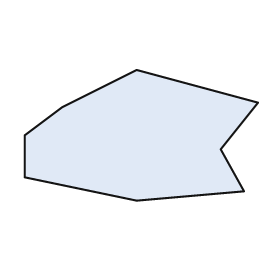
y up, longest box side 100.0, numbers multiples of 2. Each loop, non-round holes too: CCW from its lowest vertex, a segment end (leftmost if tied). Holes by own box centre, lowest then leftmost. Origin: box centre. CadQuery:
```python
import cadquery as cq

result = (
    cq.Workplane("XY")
    .moveTo(-2.0, -28.0)
    .lineTo(44.0, -24.0)
    .lineTo(34.0, -6.0)
    .lineTo(50.0, 14.0)
    .lineTo(-2.0, 28.0)
    .lineTo(-34.0, 12.0)
    .lineTo(-50.0, 0.0)
    .lineTo(-50.0, -18.0)
    .close()
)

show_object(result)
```